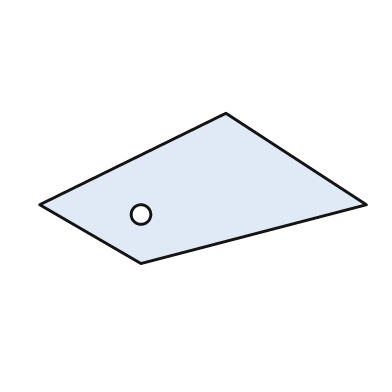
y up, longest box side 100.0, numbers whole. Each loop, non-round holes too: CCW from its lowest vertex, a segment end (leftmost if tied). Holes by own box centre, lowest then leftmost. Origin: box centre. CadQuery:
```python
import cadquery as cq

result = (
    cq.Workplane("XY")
    .moveTo(-19.0, -23.0)
    .lineTo(50.0, -5.0)
    .lineTo(7.0, 23.0)
    .lineTo(-50.0, -5.0)
    .close()
    .moveTo(-19.0, -8.0)
    .circle(3.0)
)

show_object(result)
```